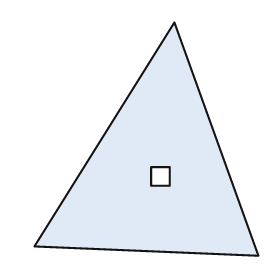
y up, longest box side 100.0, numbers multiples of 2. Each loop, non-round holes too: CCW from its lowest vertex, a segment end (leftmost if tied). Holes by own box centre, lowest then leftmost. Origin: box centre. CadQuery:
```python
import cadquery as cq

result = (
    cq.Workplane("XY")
    .moveTo(48.0, -50.0)
    .lineTo(12.0, 50.0)
    .lineTo(-48.0, -46.0)
    .close()
    .moveTo(2.0, -20.0)
    .lineTo(10.0, -20.0)
    .lineTo(10.0, -12.0)
    .lineTo(2.0, -12.0)
    .close()
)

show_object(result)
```